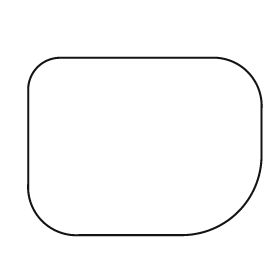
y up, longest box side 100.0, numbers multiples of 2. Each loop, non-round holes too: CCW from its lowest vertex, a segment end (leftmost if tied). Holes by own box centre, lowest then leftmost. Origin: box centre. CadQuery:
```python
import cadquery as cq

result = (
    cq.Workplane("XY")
    .moveTo(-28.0, -38.0)
    .lineTo(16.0, -38.0)
    .threePointArc((40.0, -28.0), (50.0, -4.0))
    .lineTo(50.0, 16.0)
    .threePointArc((44.0, 32.0), (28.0, 38.0))
    .lineTo(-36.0, 38.0)
    .threePointArc((-46.0, 34.0), (-50.0, 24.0))
    .lineTo(-50.0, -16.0)
    .threePointArc((-44.0, -32.0), (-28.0, -38.0))
    .close()
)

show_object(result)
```